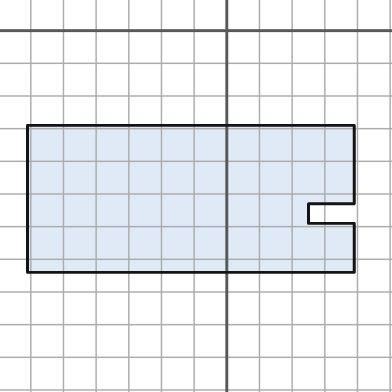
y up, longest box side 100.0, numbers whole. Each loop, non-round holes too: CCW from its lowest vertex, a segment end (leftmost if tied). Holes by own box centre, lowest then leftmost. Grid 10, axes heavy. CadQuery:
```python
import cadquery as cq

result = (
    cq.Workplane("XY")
    .moveTo(-61.0, -74.0)
    .lineTo(39.0, -74.0)
    .lineTo(39.0, -59.0)
    .lineTo(25.0, -59.0)
    .lineTo(25.0, -53.0)
    .lineTo(39.0, -53.0)
    .lineTo(39.0, -29.0)
    .lineTo(-61.0, -29.0)
    .close()
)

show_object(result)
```